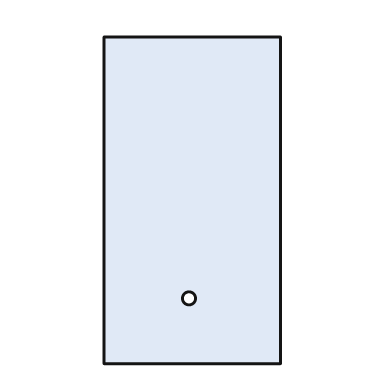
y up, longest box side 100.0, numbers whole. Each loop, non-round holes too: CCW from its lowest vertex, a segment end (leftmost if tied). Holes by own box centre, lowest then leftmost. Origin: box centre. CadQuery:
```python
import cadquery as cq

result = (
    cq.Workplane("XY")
    .moveTo(-27.0, -50.0)
    .lineTo(27.0, -50.0)
    .lineTo(27.0, 50.0)
    .lineTo(-27.0, 50.0)
    .close()
    .moveTo(-1.0, -30.0)
    .circle(2.0)
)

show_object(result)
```